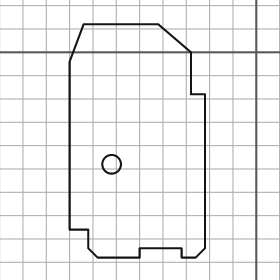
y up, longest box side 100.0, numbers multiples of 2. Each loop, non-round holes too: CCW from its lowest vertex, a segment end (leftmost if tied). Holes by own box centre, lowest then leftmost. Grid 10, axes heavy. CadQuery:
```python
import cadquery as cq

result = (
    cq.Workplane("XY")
    .moveTo(-68.0, -88.0)
    .lineTo(-50.0, -88.0)
    .lineTo(-50.0, -84.0)
    .lineTo(-32.0, -84.0)
    .lineTo(-32.0, -88.0)
    .lineTo(-26.0, -88.0)
    .lineTo(-22.0, -84.0)
    .lineTo(-22.0, -18.0)
    .lineTo(-28.0, -18.0)
    .lineTo(-28.0, 0.0)
    .lineTo(-42.0, 12.0)
    .lineTo(-74.0, 12.0)
    .lineTo(-80.0, -4.0)
    .lineTo(-80.0, -76.0)
    .lineTo(-72.0, -76.0)
    .lineTo(-72.0, -84.0)
    .close()
    .moveTo(-62.0, -48.0)
    .circle(4.0)
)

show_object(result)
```